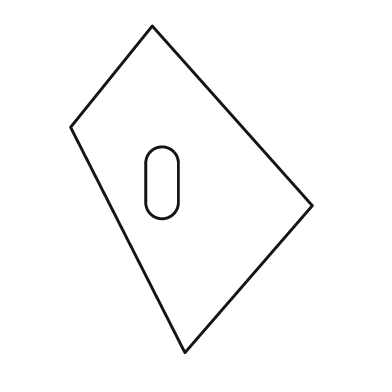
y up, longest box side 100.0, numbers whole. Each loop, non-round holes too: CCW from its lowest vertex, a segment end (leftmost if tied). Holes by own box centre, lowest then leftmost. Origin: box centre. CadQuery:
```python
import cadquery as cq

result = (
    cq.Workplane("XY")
    .moveTo(-2.0, -50.0)
    .lineTo(37.0, -5.0)
    .lineTo(-12.0, 50.0)
    .lineTo(-37.0, 19.0)
    .close()
    .moveTo(-14.0, -4.0)
    .threePointArc((-9.0, -9.0), (-4.0, -4.0))
    .lineTo(-4.0, 8.0)
    .threePointArc((-9.0, 13.0), (-14.0, 8.0))
    .close()
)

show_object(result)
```